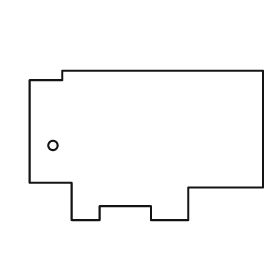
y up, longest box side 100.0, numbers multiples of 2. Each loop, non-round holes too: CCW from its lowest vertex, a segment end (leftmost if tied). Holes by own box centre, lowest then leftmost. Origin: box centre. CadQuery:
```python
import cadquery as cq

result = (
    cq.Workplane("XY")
    .moveTo(-32.0, -32.0)
    .lineTo(-20.0, -32.0)
    .lineTo(-20.0, -26.0)
    .lineTo(2.0, -26.0)
    .lineTo(2.0, -32.0)
    .lineTo(18.0, -32.0)
    .lineTo(18.0, -18.0)
    .lineTo(50.0, -18.0)
    .lineTo(50.0, 32.0)
    .lineTo(-36.0, 32.0)
    .lineTo(-36.0, 28.0)
    .lineTo(-50.0, 28.0)
    .lineTo(-50.0, -16.0)
    .lineTo(-32.0, -16.0)
    .close()
    .moveTo(-40.0, 0.0)
    .circle(2.0)
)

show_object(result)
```